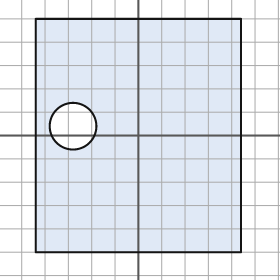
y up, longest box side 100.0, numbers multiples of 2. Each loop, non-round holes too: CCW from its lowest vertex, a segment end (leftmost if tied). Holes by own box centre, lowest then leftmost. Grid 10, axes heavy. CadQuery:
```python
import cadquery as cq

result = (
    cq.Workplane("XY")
    .moveTo(-44.0, -50.0)
    .lineTo(44.0, -50.0)
    .lineTo(44.0, 50.0)
    .lineTo(-44.0, 50.0)
    .close()
    .moveTo(-28.0, 4.0)
    .circle(10.0)
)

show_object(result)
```